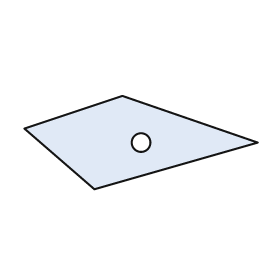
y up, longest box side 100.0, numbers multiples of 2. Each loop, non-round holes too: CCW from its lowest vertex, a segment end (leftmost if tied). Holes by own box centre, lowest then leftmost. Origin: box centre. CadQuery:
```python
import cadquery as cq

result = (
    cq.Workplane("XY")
    .moveTo(-20.0, -20.0)
    .lineTo(50.0, 0.0)
    .lineTo(-8.0, 20.0)
    .lineTo(-50.0, 6.0)
    .close()
    .moveTo(0.0, 0.0)
    .circle(4.0)
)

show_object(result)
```